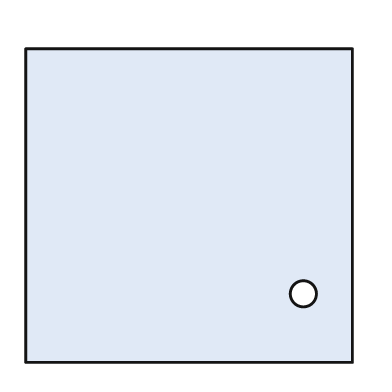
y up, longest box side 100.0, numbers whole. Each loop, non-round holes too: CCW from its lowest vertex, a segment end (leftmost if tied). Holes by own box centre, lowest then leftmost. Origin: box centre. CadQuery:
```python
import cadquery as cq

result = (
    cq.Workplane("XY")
    .moveTo(-50.0, -48.0)
    .lineTo(50.0, -48.0)
    .lineTo(50.0, 48.0)
    .lineTo(-50.0, 48.0)
    .close()
    .moveTo(35.0, -27.0)
    .circle(4.0)
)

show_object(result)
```